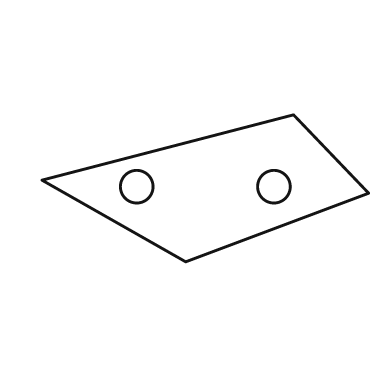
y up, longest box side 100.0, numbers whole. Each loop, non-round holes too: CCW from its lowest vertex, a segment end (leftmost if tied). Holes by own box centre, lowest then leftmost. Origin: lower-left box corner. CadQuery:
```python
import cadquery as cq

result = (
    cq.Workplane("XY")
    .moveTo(44.0, 0.0)
    .lineTo(100.0, 21.0)
    .lineTo(77.0, 45.0)
    .lineTo(0.0, 25.0)
    .close()
    .moveTo(29.0, 23.0)
    .circle(5.0)
    .moveTo(71.0, 23.0)
    .circle(5.0)
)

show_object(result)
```